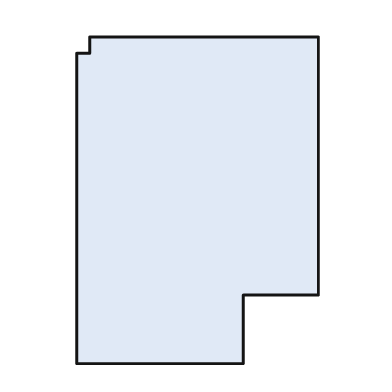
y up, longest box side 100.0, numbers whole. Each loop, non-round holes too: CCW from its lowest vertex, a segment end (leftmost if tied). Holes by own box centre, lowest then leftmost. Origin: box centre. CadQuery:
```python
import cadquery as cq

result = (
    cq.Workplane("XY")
    .moveTo(-37.0, -50.0)
    .lineTo(14.0, -50.0)
    .lineTo(14.0, -29.0)
    .lineTo(37.0, -29.0)
    .lineTo(37.0, 50.0)
    .lineTo(-33.0, 50.0)
    .lineTo(-33.0, 45.0)
    .lineTo(-37.0, 45.0)
    .close()
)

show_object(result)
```